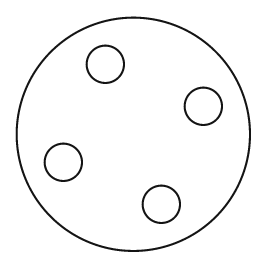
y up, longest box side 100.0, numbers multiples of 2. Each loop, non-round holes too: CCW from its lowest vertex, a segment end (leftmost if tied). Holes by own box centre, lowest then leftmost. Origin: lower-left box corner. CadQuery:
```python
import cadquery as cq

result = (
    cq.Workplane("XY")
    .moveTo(50.0, 50.0)
    .circle(50.0)
    .moveTo(62.0, 20.0)
    .circle(8.0)
    .moveTo(20.0, 38.0)
    .circle(8.0)
    .moveTo(80.0, 62.0)
    .circle(8.0)
    .moveTo(38.0, 80.0)
    .circle(8.0)
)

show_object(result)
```